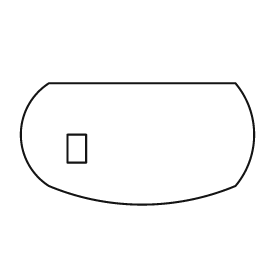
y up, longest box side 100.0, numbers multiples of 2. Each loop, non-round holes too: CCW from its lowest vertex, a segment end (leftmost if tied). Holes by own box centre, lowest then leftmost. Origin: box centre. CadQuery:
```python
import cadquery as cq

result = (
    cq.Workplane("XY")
    .moveTo(-38.0, -18.0)
    .threePointArc((2.0, -26.0), (42.0, -18.0))
    .threePointArc((50.0, 4.0), (42.0, 26.0))
    .lineTo(-38.0, 26.0)
    .threePointArc((-50.0, 4.0), (-38.0, -18.0))
    .close()
    .moveTo(-30.0, -8.0)
    .lineTo(-22.0, -8.0)
    .lineTo(-22.0, 4.0)
    .lineTo(-30.0, 4.0)
    .close()
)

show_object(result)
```